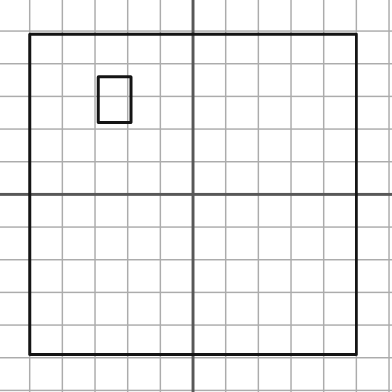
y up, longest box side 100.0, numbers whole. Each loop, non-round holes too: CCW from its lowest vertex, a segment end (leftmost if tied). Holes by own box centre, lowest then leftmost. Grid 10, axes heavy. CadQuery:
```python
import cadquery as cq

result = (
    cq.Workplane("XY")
    .moveTo(-50.0, -49.0)
    .lineTo(50.0, -49.0)
    .lineTo(50.0, 49.0)
    .lineTo(-50.0, 49.0)
    .close()
    .moveTo(-29.0, 22.0)
    .lineTo(-19.0, 22.0)
    .lineTo(-19.0, 36.0)
    .lineTo(-29.0, 36.0)
    .close()
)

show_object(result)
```